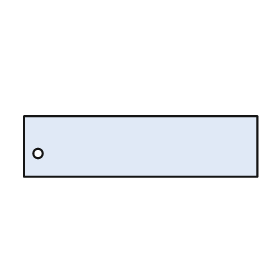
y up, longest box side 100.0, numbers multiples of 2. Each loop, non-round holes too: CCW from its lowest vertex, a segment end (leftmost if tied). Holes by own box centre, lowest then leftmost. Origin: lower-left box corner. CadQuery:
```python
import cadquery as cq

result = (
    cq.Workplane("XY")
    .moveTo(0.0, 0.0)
    .lineTo(100.0, 0.0)
    .lineTo(100.0, 26.0)
    .lineTo(0.0, 26.0)
    .close()
    .moveTo(6.0, 10.0)
    .circle(2.0)
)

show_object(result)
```